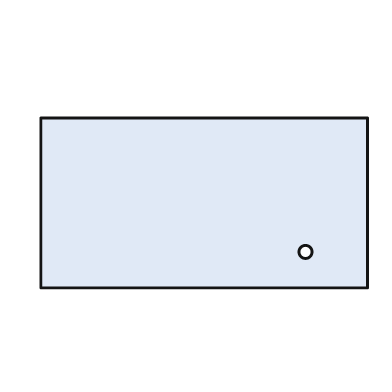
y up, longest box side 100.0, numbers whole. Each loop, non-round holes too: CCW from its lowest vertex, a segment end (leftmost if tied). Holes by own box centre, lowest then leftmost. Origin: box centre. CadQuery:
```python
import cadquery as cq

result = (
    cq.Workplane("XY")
    .moveTo(-50.0, -26.0)
    .lineTo(50.0, -26.0)
    .lineTo(50.0, 26.0)
    .lineTo(-50.0, 26.0)
    .close()
    .moveTo(31.0, -15.0)
    .circle(2.0)
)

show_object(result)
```